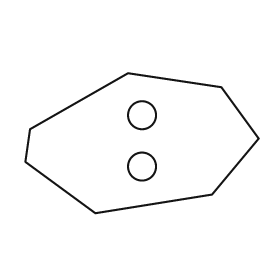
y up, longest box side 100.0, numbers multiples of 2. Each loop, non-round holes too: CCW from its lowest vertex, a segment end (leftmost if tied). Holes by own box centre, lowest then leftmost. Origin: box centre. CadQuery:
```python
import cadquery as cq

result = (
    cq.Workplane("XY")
    .moveTo(-20.0, -30.0)
    .lineTo(30.0, -22.0)
    .lineTo(50.0, 2.0)
    .lineTo(34.0, 24.0)
    .lineTo(-6.0, 30.0)
    .lineTo(-48.0, 6.0)
    .lineTo(-50.0, -8.0)
    .close()
    .moveTo(0.0, -10.0)
    .circle(6.0)
    .moveTo(0.0, 12.0)
    .circle(6.0)
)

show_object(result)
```